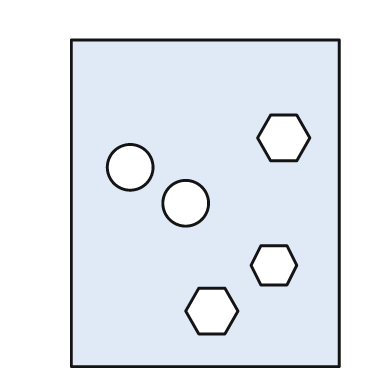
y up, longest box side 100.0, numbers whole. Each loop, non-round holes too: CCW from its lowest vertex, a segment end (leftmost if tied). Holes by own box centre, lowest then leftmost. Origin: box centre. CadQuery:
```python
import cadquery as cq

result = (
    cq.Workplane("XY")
    .moveTo(-41.0, -50.0)
    .lineTo(41.0, -50.0)
    .lineTo(41.0, 50.0)
    .lineTo(-41.0, 50.0)
    .close()
    .moveTo(-2.0, -40.0)
    .lineTo(6.0, -40.0)
    .lineTo(10.0, -33.0)
    .lineTo(6.0, -26.0)
    .lineTo(-2.0, -26.0)
    .lineTo(-6.0, -33.0)
    .close()
    .moveTo(17.0, -25.0)
    .lineTo(25.0, -25.0)
    .lineTo(28.0, -19.0)
    .lineTo(25.0, -13.0)
    .lineTo(17.0, -13.0)
    .lineTo(14.0, -19.0)
    .close()
    .moveTo(-6.0, 0.0)
    .circle(7.0)
    .moveTo(-23.0, 11.0)
    .circle(7.0)
    .moveTo(20.0, 13.0)
    .lineTo(28.0, 13.0)
    .lineTo(32.0, 20.0)
    .lineTo(28.0, 27.0)
    .lineTo(20.0, 27.0)
    .lineTo(16.0, 20.0)
    .close()
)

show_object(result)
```